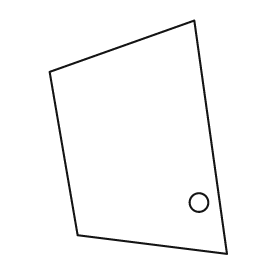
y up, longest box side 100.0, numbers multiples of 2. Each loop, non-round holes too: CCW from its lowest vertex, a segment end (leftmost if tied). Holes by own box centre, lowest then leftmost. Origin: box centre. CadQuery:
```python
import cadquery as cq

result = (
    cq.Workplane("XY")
    .moveTo(38.0, -50.0)
    .lineTo(24.0, 50.0)
    .lineTo(-38.0, 28.0)
    .lineTo(-26.0, -42.0)
    .close()
    .moveTo(26.0, -28.0)
    .circle(4.0)
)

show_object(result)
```